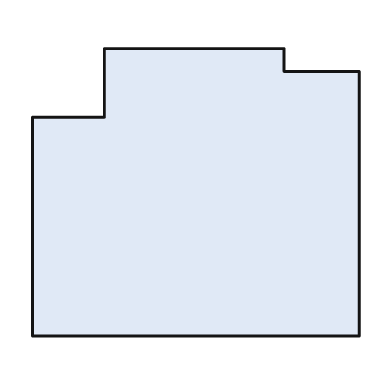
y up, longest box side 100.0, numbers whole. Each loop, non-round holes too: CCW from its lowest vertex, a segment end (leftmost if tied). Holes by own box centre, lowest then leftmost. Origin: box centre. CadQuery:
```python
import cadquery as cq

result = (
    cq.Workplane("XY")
    .moveTo(-50.0, -44.0)
    .lineTo(50.0, -44.0)
    .lineTo(50.0, 37.0)
    .lineTo(27.0, 37.0)
    .lineTo(27.0, 44.0)
    .lineTo(-28.0, 44.0)
    .lineTo(-28.0, 23.0)
    .lineTo(-50.0, 23.0)
    .close()
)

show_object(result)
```